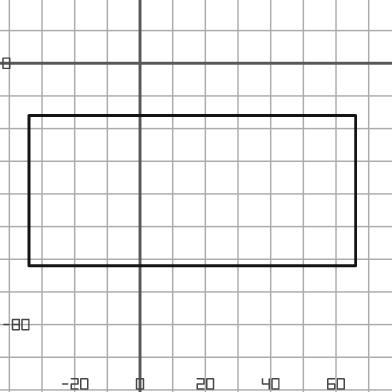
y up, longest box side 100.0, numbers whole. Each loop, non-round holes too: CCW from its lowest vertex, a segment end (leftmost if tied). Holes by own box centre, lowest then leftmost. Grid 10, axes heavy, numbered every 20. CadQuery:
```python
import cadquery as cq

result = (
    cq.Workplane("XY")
    .moveTo(-34.0, -62.0)
    .lineTo(66.0, -62.0)
    .lineTo(66.0, -16.0)
    .lineTo(-34.0, -16.0)
    .close()
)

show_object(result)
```